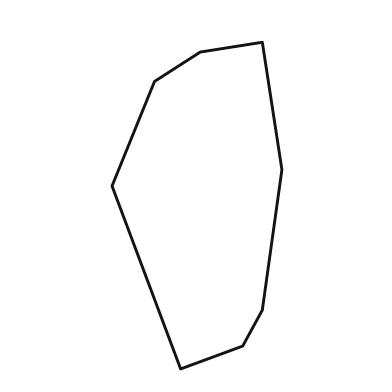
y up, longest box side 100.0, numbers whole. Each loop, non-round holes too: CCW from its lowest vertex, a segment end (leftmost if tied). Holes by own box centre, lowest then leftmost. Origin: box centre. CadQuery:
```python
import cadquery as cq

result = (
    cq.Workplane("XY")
    .moveTo(-5.0, -50.0)
    .lineTo(14.0, -43.0)
    .lineTo(20.0, -32.0)
    .lineTo(26.0, 11.0)
    .lineTo(20.0, 50.0)
    .lineTo(1.0, 47.0)
    .lineTo(-13.0, 38.0)
    .lineTo(-26.0, 6.0)
    .close()
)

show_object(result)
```